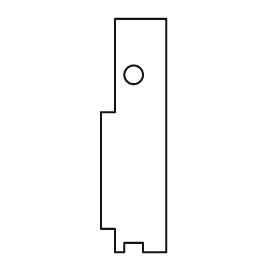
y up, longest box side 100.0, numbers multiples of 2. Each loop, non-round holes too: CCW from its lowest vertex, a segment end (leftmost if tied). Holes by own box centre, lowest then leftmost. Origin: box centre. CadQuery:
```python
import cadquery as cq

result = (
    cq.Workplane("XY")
    .moveTo(-8.0, -50.0)
    .lineTo(-4.0, -50.0)
    .lineTo(-4.0, -46.0)
    .lineTo(4.0, -46.0)
    .lineTo(4.0, -50.0)
    .lineTo(14.0, -50.0)
    .lineTo(14.0, 50.0)
    .lineTo(-8.0, 50.0)
    .lineTo(-8.0, 10.0)
    .lineTo(-14.0, 10.0)
    .lineTo(-14.0, -40.0)
    .lineTo(-8.0, -40.0)
    .close()
    .moveTo(0.0, 26.0)
    .circle(4.0)
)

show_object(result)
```